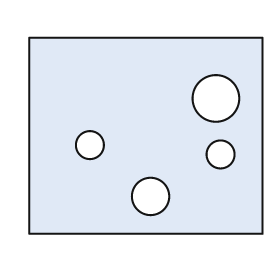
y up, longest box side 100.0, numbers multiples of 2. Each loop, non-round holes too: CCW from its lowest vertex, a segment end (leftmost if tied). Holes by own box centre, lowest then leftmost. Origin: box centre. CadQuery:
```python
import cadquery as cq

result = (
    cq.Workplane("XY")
    .moveTo(-50.0, -42.0)
    .lineTo(50.0, -42.0)
    .lineTo(50.0, 42.0)
    .lineTo(-50.0, 42.0)
    .close()
    .moveTo(2.0, -26.0)
    .circle(8.0)
    .moveTo(32.0, -8.0)
    .circle(6.0)
    .moveTo(-24.0, -4.0)
    .circle(6.0)
    .moveTo(30.0, 16.0)
    .circle(10.0)
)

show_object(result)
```